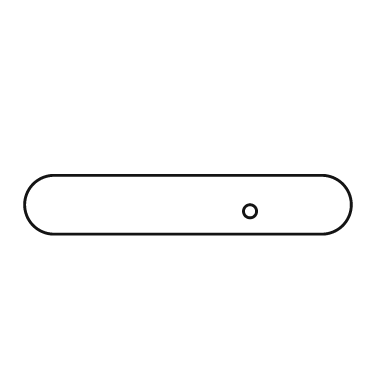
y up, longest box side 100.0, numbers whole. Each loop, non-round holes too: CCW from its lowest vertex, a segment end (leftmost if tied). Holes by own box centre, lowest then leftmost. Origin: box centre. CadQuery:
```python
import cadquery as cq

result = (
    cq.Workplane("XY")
    .moveTo(-41.0, -9.0)
    .lineTo(41.0, -9.0)
    .threePointArc((50.0, 0.0), (41.0, 9.0))
    .lineTo(-41.0, 9.0)
    .threePointArc((-50.0, 0.0), (-41.0, -9.0))
    .close()
    .moveTo(19.0, -2.0)
    .circle(2.0)
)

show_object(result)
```